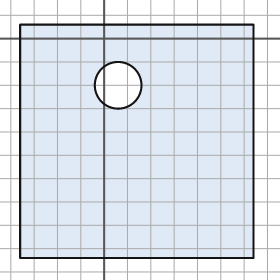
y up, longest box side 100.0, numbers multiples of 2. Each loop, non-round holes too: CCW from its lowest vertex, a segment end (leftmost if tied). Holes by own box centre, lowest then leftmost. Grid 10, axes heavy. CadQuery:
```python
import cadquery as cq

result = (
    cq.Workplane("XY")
    .moveTo(-36.0, -94.0)
    .lineTo(64.0, -94.0)
    .lineTo(64.0, 6.0)
    .lineTo(-36.0, 6.0)
    .close()
    .moveTo(6.0, -20.0)
    .circle(10.0)
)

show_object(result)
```